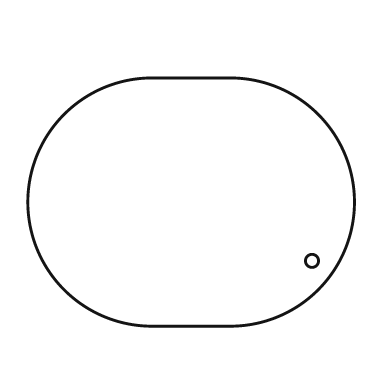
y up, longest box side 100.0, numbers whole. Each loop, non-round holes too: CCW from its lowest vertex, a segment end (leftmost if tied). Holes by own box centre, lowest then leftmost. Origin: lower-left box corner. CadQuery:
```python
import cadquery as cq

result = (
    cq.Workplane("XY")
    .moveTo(38.0, 0.0)
    .lineTo(62.0, 0.0)
    .threePointArc((100.0, 38.0), (62.0, 76.0))
    .lineTo(38.0, 76.0)
    .threePointArc((0.0, 38.0), (38.0, 0.0))
    .close()
    .moveTo(87.0, 20.0)
    .circle(2.0)
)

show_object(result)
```